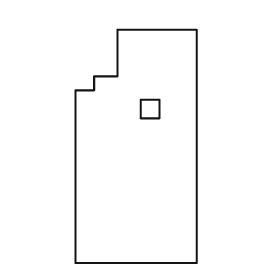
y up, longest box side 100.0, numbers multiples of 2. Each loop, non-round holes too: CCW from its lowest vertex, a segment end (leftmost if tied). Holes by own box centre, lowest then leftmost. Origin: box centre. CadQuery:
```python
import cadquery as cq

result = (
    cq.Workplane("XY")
    .moveTo(-26.0, -50.0)
    .lineTo(26.0, -50.0)
    .lineTo(26.0, 50.0)
    .lineTo(-8.0, 50.0)
    .lineTo(-8.0, 30.0)
    .lineTo(-18.0, 30.0)
    .lineTo(-18.0, 24.0)
    .lineTo(-26.0, 24.0)
    .close()
    .moveTo(2.0, 12.0)
    .lineTo(10.0, 12.0)
    .lineTo(10.0, 20.0)
    .lineTo(2.0, 20.0)
    .close()
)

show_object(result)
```